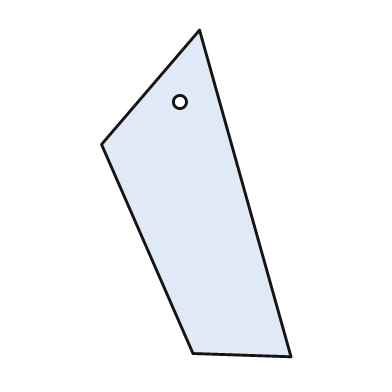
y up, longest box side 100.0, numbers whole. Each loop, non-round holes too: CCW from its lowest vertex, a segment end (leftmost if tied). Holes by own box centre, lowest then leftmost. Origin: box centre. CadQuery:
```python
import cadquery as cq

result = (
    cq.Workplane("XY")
    .moveTo(29.0, -50.0)
    .lineTo(1.0, 50.0)
    .lineTo(-29.0, 15.0)
    .lineTo(-1.0, -49.0)
    .close()
    .moveTo(-5.0, 28.0)
    .circle(2.0)
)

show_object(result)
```